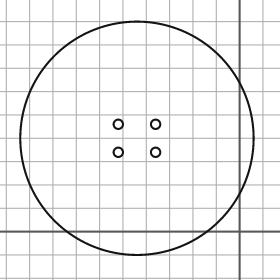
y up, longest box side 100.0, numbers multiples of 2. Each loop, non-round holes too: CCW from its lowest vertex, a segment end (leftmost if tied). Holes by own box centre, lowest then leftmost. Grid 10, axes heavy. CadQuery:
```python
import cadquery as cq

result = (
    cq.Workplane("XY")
    .moveTo(-44.0, 40.0)
    .circle(50.0)
    .moveTo(-52.0, 34.0)
    .circle(2.0)
    .moveTo(-36.0, 34.0)
    .circle(2.0)
    .moveTo(-52.0, 46.0)
    .circle(2.0)
    .moveTo(-36.0, 46.0)
    .circle(2.0)
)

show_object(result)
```